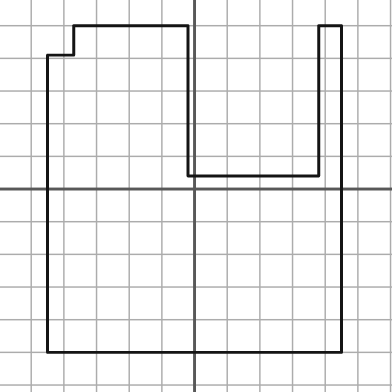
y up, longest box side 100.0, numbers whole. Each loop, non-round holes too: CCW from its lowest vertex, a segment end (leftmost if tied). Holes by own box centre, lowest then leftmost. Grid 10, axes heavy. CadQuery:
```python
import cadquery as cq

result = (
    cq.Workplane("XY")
    .moveTo(-45.0, -50.0)
    .lineTo(45.0, -50.0)
    .lineTo(45.0, 50.0)
    .lineTo(38.0, 50.0)
    .lineTo(38.0, 4.0)
    .lineTo(-2.0, 4.0)
    .lineTo(-2.0, 50.0)
    .lineTo(-37.0, 50.0)
    .lineTo(-37.0, 41.0)
    .lineTo(-45.0, 41.0)
    .close()
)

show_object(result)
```